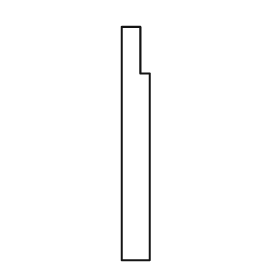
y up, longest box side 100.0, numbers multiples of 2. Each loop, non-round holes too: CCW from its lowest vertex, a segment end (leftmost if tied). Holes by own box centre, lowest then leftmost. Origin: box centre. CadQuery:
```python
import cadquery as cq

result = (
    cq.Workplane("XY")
    .moveTo(-6.0, -50.0)
    .lineTo(6.0, -50.0)
    .lineTo(6.0, 30.0)
    .lineTo(2.0, 30.0)
    .lineTo(2.0, 50.0)
    .lineTo(-6.0, 50.0)
    .close()
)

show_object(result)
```